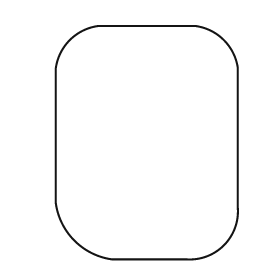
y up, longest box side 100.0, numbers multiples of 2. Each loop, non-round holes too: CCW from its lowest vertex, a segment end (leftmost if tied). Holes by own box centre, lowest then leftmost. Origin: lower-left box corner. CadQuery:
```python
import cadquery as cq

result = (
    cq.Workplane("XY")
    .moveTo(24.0, 0.0)
    .lineTo(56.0, 0.0)
    .threePointArc((72.0, 6.0), (78.0, 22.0))
    .lineTo(78.0, 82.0)
    .threePointArc((72.0, 94.0), (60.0, 100.0))
    .lineTo(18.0, 100.0)
    .threePointArc((6.0, 94.0), (0.0, 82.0))
    .lineTo(0.0, 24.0)
    .threePointArc((8.0, 8.0), (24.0, 0.0))
    .close()
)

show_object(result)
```